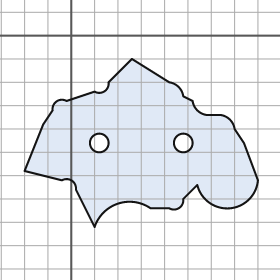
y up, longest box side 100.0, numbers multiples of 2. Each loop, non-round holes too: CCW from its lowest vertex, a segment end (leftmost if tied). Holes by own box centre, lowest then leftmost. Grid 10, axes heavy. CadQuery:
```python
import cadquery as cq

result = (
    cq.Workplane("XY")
    .moveTo(10.0, -82.0)
    .threePointArc((20.0, -72.0), (34.0, -74.0))
    .lineTo(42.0, -74.0)
    .threePointArc((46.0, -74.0), (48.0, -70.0))
    .lineTo(54.0, -64.0)
    .threePointArc((68.0, -74.0), (80.0, -62.0))
    .lineTo(74.0, -46.0)
    .lineTo(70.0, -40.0)
    .threePointArc((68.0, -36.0), (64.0, -34.0))
    .lineTo(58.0, -34.0)
    .threePointArc((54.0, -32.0), (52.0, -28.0))
    .lineTo(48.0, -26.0)
    .threePointArc((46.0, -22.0), (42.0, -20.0))
    .lineTo(26.0, -10.0)
    .lineTo(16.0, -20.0)
    .threePointArc((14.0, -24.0), (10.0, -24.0))
    .lineTo(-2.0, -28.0)
    .threePointArc((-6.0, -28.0), (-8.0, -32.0))
    .lineTo(-12.0, -38.0)
    .lineTo(-20.0, -58.0)
    .lineTo(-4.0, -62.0)
    .threePointArc((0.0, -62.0), (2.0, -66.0))
    .close()
    .moveTo(12.0, -46.0)
    .circle(4.0)
    .moveTo(48.0, -46.0)
    .circle(4.0)
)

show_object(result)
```